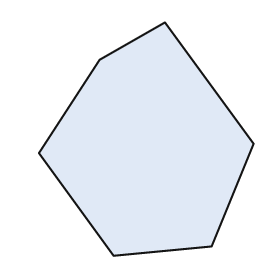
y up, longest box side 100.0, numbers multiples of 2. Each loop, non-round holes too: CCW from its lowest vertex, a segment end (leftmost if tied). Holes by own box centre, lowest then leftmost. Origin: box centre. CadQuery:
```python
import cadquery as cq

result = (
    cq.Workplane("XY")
    .moveTo(-14.0, -50.0)
    .lineTo(28.0, -46.0)
    .lineTo(46.0, -2.0)
    .lineTo(8.0, 50.0)
    .lineTo(-20.0, 34.0)
    .lineTo(-46.0, -6.0)
    .close()
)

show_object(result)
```